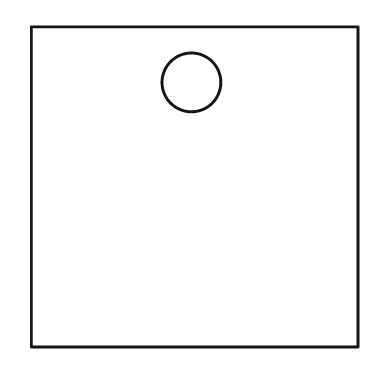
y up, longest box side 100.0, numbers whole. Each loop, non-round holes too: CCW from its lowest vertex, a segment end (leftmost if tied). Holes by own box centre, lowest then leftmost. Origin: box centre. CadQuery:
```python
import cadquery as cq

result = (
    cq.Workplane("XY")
    .moveTo(-50.0, -49.0)
    .lineTo(50.0, -49.0)
    .lineTo(50.0, 49.0)
    .lineTo(-50.0, 49.0)
    .close()
    .moveTo(-1.0, 32.0)
    .circle(9.0)
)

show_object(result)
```